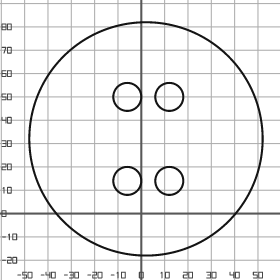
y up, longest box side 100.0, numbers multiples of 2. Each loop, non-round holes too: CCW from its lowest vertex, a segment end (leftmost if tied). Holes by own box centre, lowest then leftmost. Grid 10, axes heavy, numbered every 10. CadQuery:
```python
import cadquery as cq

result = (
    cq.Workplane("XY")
    .moveTo(2.0, 32.0)
    .circle(50.0)
    .moveTo(-6.0, 14.0)
    .circle(6.0)
    .moveTo(12.0, 14.0)
    .circle(6.0)
    .moveTo(-6.0, 50.0)
    .circle(6.0)
    .moveTo(12.0, 50.0)
    .circle(6.0)
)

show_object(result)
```